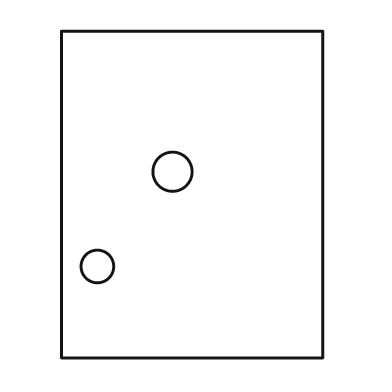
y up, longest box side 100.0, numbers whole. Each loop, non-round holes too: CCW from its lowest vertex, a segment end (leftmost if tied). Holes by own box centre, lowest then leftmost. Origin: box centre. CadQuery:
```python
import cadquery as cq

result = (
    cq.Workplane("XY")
    .moveTo(-40.0, -50.0)
    .lineTo(40.0, -50.0)
    .lineTo(40.0, 50.0)
    .lineTo(-40.0, 50.0)
    .close()
    .moveTo(-29.0, -22.0)
    .circle(5.0)
    .moveTo(-6.0, 7.0)
    .circle(6.0)
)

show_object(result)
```